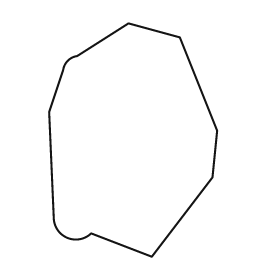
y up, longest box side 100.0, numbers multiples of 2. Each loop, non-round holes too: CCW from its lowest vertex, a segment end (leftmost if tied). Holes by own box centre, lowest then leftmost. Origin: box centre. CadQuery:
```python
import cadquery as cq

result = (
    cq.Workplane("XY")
    .moveTo(8.0, -50.0)
    .lineTo(34.0, -16.0)
    .lineTo(36.0, 4.0)
    .lineTo(20.0, 44.0)
    .lineTo(-2.0, 50.0)
    .lineTo(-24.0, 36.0)
    .threePointArc((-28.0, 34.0), (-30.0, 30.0))
    .lineTo(-36.0, 12.0)
    .lineTo(-34.0, -34.0)
    .threePointArc((-28.0, -42.0), (-18.0, -40.0))
    .close()
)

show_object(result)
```